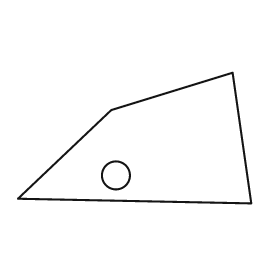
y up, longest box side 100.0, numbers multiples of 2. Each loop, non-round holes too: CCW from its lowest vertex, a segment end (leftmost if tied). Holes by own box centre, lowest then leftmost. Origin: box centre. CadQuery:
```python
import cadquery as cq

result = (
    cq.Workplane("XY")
    .moveTo(50.0, -28.0)
    .lineTo(42.0, 28.0)
    .lineTo(-10.0, 12.0)
    .lineTo(-50.0, -26.0)
    .close()
    .moveTo(-8.0, -16.0)
    .circle(6.0)
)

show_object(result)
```